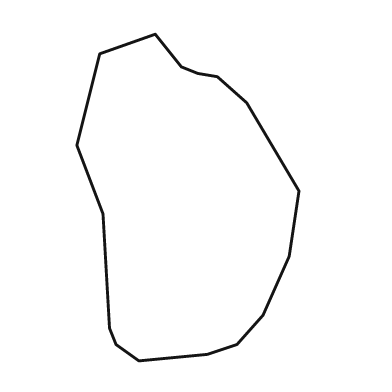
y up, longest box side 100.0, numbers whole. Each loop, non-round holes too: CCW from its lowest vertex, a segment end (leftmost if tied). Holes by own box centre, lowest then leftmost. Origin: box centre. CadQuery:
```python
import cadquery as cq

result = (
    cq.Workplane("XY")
    .moveTo(-15.0, -50.0)
    .lineTo(6.0, -48.0)
    .lineTo(15.0, -45.0)
    .lineTo(23.0, -36.0)
    .lineTo(31.0, -18.0)
    .lineTo(34.0, 2.0)
    .lineTo(18.0, 29.0)
    .lineTo(9.0, 37.0)
    .lineTo(3.0, 38.0)
    .lineTo(-2.0, 40.0)
    .lineTo(-10.0, 50.0)
    .lineTo(-27.0, 44.0)
    .lineTo(-34.0, 16.0)
    .lineTo(-26.0, -5.0)
    .lineTo(-24.0, -40.0)
    .lineTo(-22.0, -45.0)
    .close()
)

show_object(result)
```